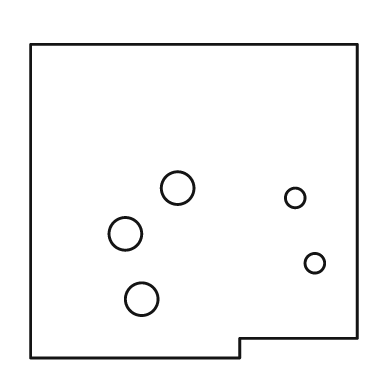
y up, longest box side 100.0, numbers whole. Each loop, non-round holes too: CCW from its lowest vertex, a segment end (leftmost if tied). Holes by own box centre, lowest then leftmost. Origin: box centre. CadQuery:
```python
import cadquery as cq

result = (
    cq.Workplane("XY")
    .moveTo(-50.0, -48.0)
    .lineTo(14.0, -48.0)
    .lineTo(14.0, -42.0)
    .lineTo(50.0, -42.0)
    .lineTo(50.0, 48.0)
    .lineTo(-50.0, 48.0)
    .close()
    .moveTo(-16.0, -30.0)
    .circle(5.0)
    .moveTo(37.0, -19.0)
    .circle(3.0)
    .moveTo(-21.0, -10.0)
    .circle(5.0)
    .moveTo(31.0, 1.0)
    .circle(3.0)
    .moveTo(-5.0, 4.0)
    .circle(5.0)
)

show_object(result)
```